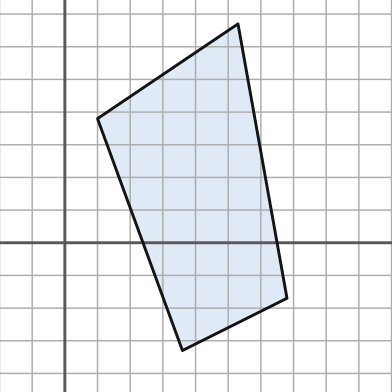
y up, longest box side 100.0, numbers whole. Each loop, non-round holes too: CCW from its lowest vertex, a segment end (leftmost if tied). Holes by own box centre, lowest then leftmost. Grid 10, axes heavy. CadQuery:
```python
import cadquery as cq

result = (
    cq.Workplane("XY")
    .moveTo(36.0, -33.0)
    .lineTo(68.0, -17.0)
    .lineTo(53.0, 67.0)
    .lineTo(10.0, 38.0)
    .close()
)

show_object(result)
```